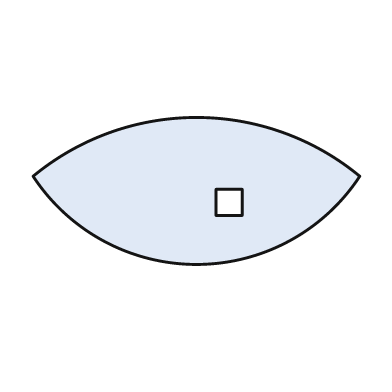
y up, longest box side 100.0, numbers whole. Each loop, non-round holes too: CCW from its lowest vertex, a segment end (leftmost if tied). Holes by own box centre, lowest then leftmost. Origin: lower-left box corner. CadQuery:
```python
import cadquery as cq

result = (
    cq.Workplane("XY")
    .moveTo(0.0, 27.0)
    .threePointArc((50.0, 0.0), (100.0, 27.0))
    .threePointArc((50.0, 45.0), (0.0, 27.0))
    .close()
    .moveTo(56.0, 15.0)
    .lineTo(64.0, 15.0)
    .lineTo(64.0, 23.0)
    .lineTo(56.0, 23.0)
    .close()
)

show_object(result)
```